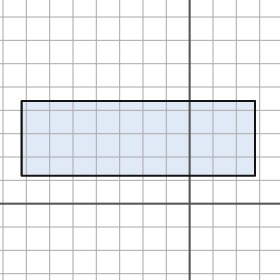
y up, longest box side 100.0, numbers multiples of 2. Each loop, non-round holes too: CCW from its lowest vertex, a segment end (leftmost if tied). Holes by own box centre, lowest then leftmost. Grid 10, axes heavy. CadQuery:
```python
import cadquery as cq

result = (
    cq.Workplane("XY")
    .moveTo(-72.0, 12.0)
    .lineTo(28.0, 12.0)
    .lineTo(28.0, 44.0)
    .lineTo(-72.0, 44.0)
    .close()
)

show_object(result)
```